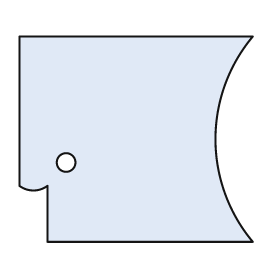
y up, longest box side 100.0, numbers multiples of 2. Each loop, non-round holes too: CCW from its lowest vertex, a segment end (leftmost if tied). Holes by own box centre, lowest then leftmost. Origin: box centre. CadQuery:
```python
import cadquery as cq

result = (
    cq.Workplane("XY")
    .moveTo(-38.0, -44.0)
    .lineTo(50.0, -44.0)
    .threePointArc((34.0, 0.0), (50.0, 44.0))
    .lineTo(-50.0, 44.0)
    .lineTo(-50.0, -20.0)
    .threePointArc((-44.0, -22.0), (-38.0, -20.0))
    .close()
    .moveTo(-30.0, -10.0)
    .circle(4.0)
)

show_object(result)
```